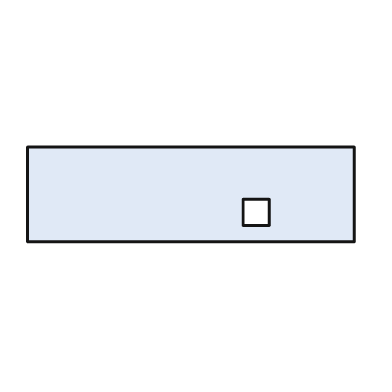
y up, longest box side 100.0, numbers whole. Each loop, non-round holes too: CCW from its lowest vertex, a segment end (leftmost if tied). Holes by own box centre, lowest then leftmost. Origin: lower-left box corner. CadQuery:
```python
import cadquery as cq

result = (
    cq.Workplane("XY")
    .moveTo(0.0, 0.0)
    .lineTo(100.0, 0.0)
    .lineTo(100.0, 29.0)
    .lineTo(0.0, 29.0)
    .close()
    .moveTo(66.0, 5.0)
    .lineTo(74.0, 5.0)
    .lineTo(74.0, 13.0)
    .lineTo(66.0, 13.0)
    .close()
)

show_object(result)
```